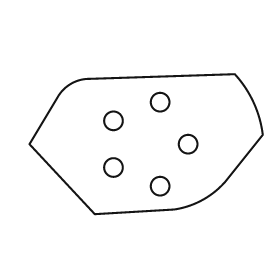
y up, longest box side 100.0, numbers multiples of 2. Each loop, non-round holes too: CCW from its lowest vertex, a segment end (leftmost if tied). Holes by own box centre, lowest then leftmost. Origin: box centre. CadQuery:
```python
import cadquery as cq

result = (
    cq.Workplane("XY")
    .moveTo(-22.0, -30.0)
    .lineTo(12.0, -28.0)
    .threePointArc((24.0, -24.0), (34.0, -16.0))
    .lineTo(50.0, 4.0)
    .threePointArc((46.0, 18.0), (38.0, 30.0))
    .lineTo(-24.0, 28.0)
    .threePointArc((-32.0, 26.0), (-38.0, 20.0))
    .lineTo(-50.0, 0.0)
    .close()
    .moveTo(6.0, -18.0)
    .circle(4.0)
    .moveTo(-14.0, -10.0)
    .circle(4.0)
    .moveTo(18.0, 0.0)
    .circle(4.0)
    .moveTo(-14.0, 10.0)
    .circle(4.0)
    .moveTo(6.0, 18.0)
    .circle(4.0)
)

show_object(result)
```